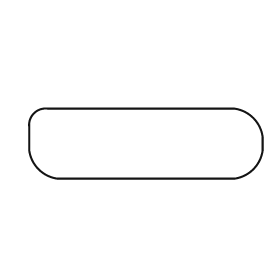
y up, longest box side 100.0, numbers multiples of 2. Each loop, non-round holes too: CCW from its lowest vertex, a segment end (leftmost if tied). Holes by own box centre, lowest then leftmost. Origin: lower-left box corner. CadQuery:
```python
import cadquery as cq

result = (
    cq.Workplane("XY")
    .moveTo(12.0, 0.0)
    .lineTo(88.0, 0.0)
    .threePointArc((96.0, 4.0), (100.0, 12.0))
    .lineTo(100.0, 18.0)
    .threePointArc((96.0, 26.0), (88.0, 30.0))
    .lineTo(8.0, 30.0)
    .threePointArc((2.0, 28.0), (0.0, 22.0))
    .lineTo(0.0, 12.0)
    .threePointArc((4.0, 4.0), (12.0, 0.0))
    .close()
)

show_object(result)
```